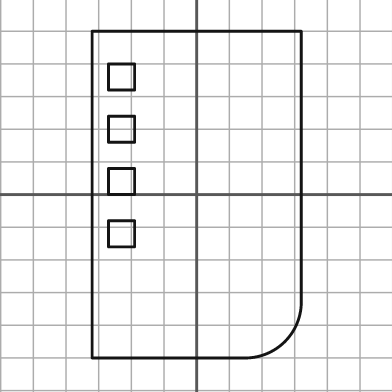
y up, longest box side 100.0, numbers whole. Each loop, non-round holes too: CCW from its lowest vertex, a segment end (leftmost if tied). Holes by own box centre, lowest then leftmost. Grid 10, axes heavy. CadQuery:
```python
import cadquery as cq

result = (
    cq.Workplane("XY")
    .moveTo(-32.0, -50.0)
    .lineTo(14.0, -50.0)
    .threePointArc((27.0, -45.0), (32.0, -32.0))
    .lineTo(32.0, 50.0)
    .lineTo(-32.0, 50.0)
    .close()
    .moveTo(-27.0, -16.0)
    .lineTo(-19.0, -16.0)
    .lineTo(-19.0, -8.0)
    .lineTo(-27.0, -8.0)
    .close()
    .moveTo(-27.0, 0.0)
    .lineTo(-19.0, 0.0)
    .lineTo(-19.0, 8.0)
    .lineTo(-27.0, 8.0)
    .close()
    .moveTo(-27.0, 16.0)
    .lineTo(-19.0, 16.0)
    .lineTo(-19.0, 24.0)
    .lineTo(-27.0, 24.0)
    .close()
    .moveTo(-27.0, 32.0)
    .lineTo(-19.0, 32.0)
    .lineTo(-19.0, 40.0)
    .lineTo(-27.0, 40.0)
    .close()
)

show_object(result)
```